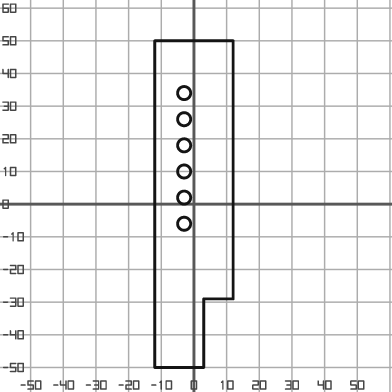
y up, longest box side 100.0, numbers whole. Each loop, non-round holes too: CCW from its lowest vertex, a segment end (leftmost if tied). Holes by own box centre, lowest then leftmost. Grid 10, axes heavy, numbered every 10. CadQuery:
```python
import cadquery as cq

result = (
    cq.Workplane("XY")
    .moveTo(-12.0, -50.0)
    .lineTo(3.0, -50.0)
    .lineTo(3.0, -29.0)
    .lineTo(12.0, -29.0)
    .lineTo(12.0, 50.0)
    .lineTo(-12.0, 50.0)
    .close()
    .moveTo(-3.0, -6.0)
    .circle(2.0)
    .moveTo(-3.0, 2.0)
    .circle(2.0)
    .moveTo(-3.0, 10.0)
    .circle(2.0)
    .moveTo(-3.0, 18.0)
    .circle(2.0)
    .moveTo(-3.0, 26.0)
    .circle(2.0)
    .moveTo(-3.0, 34.0)
    .circle(2.0)
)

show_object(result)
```